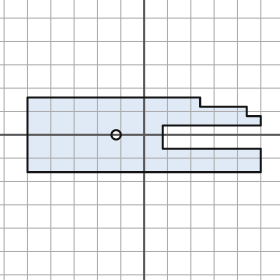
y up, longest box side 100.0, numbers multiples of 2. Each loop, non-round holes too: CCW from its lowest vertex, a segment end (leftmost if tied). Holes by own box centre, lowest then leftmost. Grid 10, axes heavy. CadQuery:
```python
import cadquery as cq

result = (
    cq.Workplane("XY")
    .moveTo(-50.0, -16.0)
    .lineTo(50.0, -16.0)
    .lineTo(50.0, -6.0)
    .lineTo(8.0, -6.0)
    .lineTo(8.0, 4.0)
    .lineTo(50.0, 4.0)
    .lineTo(50.0, 8.0)
    .lineTo(44.0, 8.0)
    .lineTo(44.0, 12.0)
    .lineTo(24.0, 12.0)
    .lineTo(24.0, 16.0)
    .lineTo(-50.0, 16.0)
    .close()
    .moveTo(-12.0, 0.0)
    .circle(2.0)
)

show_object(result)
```